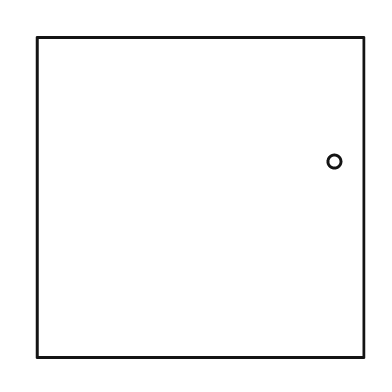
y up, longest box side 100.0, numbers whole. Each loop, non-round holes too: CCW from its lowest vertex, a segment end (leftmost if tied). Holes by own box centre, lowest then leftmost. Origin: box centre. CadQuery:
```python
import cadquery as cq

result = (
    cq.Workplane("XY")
    .moveTo(-50.0, -49.0)
    .lineTo(50.0, -49.0)
    .lineTo(50.0, 49.0)
    .lineTo(-50.0, 49.0)
    .close()
    .moveTo(41.0, 11.0)
    .circle(2.0)
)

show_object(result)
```